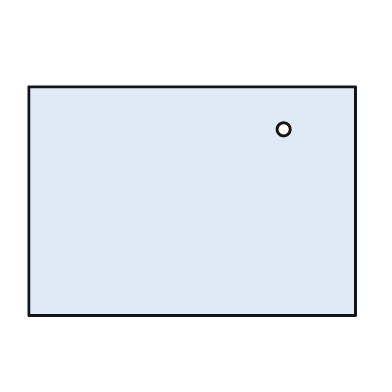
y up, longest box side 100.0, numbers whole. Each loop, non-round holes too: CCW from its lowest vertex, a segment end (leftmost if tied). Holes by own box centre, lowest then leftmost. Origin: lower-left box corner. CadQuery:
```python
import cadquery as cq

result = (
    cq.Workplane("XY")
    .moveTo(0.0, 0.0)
    .lineTo(100.0, 0.0)
    .lineTo(100.0, 70.0)
    .lineTo(0.0, 70.0)
    .close()
    .moveTo(78.0, 57.0)
    .circle(2.0)
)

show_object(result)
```